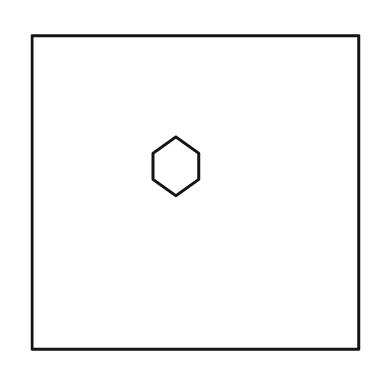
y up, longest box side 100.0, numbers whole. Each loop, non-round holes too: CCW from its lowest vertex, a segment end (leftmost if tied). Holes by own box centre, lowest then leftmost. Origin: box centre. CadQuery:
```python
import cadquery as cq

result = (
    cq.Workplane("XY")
    .moveTo(-50.0, -48.0)
    .lineTo(50.0, -48.0)
    .lineTo(50.0, 48.0)
    .lineTo(-50.0, 48.0)
    .close()
    .moveTo(-6.0, -1.0)
    .lineTo(1.0, 4.0)
    .lineTo(1.0, 12.0)
    .lineTo(-6.0, 17.0)
    .lineTo(-13.0, 12.0)
    .lineTo(-13.0, 4.0)
    .close()
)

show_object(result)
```